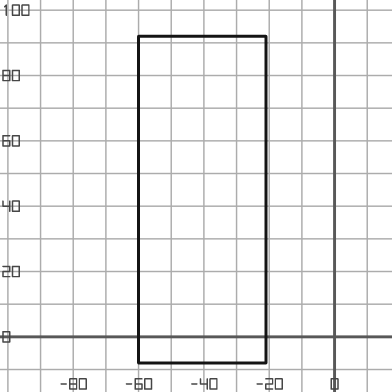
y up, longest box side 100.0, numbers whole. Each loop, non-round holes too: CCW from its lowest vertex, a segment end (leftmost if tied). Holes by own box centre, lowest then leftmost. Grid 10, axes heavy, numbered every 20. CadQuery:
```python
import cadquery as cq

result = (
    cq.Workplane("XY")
    .moveTo(-60.0, -8.0)
    .lineTo(-21.0, -8.0)
    .lineTo(-21.0, 92.0)
    .lineTo(-60.0, 92.0)
    .close()
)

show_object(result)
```